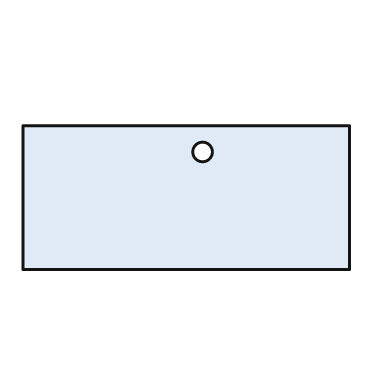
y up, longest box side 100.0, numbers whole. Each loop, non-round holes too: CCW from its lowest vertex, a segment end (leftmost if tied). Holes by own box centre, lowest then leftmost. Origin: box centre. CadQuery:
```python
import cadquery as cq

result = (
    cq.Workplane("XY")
    .moveTo(-50.0, -22.0)
    .lineTo(50.0, -22.0)
    .lineTo(50.0, 22.0)
    .lineTo(-50.0, 22.0)
    .close()
    .moveTo(5.0, 14.0)
    .circle(3.0)
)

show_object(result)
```